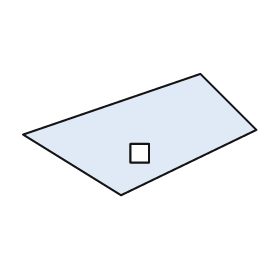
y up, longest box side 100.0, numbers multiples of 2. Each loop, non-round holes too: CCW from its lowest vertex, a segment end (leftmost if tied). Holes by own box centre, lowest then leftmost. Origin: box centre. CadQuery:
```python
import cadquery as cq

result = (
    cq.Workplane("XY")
    .moveTo(-8.0, -26.0)
    .lineTo(50.0, 2.0)
    .lineTo(26.0, 26.0)
    .lineTo(-50.0, 0.0)
    .close()
    .moveTo(-4.0, -12.0)
    .lineTo(4.0, -12.0)
    .lineTo(4.0, -4.0)
    .lineTo(-4.0, -4.0)
    .close()
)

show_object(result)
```